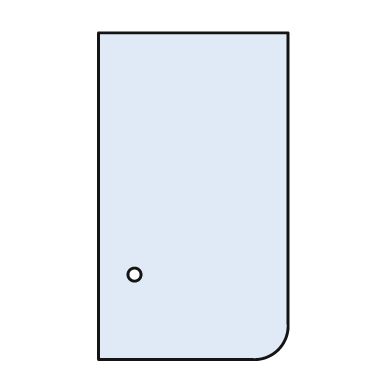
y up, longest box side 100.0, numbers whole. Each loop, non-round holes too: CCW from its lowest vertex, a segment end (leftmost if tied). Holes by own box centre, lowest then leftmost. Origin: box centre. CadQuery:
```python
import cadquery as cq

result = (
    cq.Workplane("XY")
    .moveTo(-29.0, -50.0)
    .lineTo(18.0, -50.0)
    .threePointArc((26.0, -47.0), (29.0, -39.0))
    .lineTo(29.0, 50.0)
    .lineTo(-29.0, 50.0)
    .close()
    .moveTo(-18.0, -24.0)
    .circle(2.0)
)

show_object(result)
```